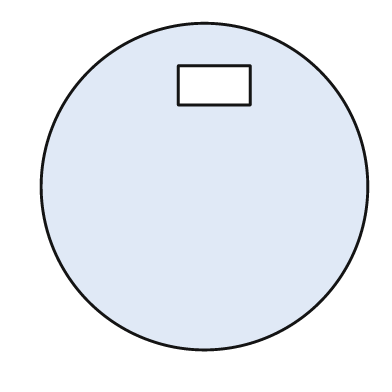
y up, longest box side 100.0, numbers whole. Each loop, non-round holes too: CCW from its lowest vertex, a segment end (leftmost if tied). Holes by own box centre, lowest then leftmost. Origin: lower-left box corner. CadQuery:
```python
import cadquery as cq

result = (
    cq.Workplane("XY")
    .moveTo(50.0, 50.0)
    .circle(50.0)
    .moveTo(42.0, 75.0)
    .lineTo(64.0, 75.0)
    .lineTo(64.0, 87.0)
    .lineTo(42.0, 87.0)
    .close()
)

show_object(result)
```